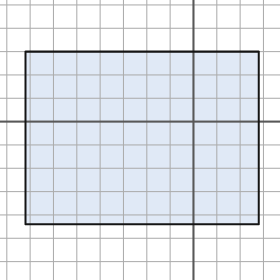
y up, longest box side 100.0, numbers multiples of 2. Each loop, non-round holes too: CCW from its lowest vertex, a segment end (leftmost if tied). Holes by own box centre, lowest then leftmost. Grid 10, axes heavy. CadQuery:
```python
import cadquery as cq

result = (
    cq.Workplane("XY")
    .moveTo(-72.0, -44.0)
    .lineTo(28.0, -44.0)
    .lineTo(28.0, 30.0)
    .lineTo(-72.0, 30.0)
    .close()
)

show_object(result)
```